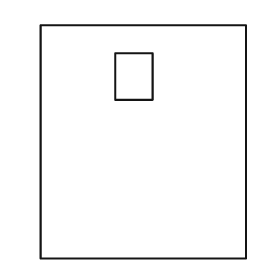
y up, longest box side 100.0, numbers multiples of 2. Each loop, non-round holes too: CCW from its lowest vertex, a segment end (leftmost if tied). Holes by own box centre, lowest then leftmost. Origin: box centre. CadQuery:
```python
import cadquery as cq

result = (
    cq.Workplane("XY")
    .moveTo(-44.0, -50.0)
    .lineTo(44.0, -50.0)
    .lineTo(44.0, 50.0)
    .lineTo(-44.0, 50.0)
    .close()
    .moveTo(-12.0, 18.0)
    .lineTo(4.0, 18.0)
    .lineTo(4.0, 38.0)
    .lineTo(-12.0, 38.0)
    .close()
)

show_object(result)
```